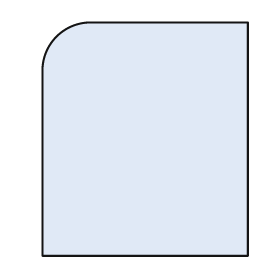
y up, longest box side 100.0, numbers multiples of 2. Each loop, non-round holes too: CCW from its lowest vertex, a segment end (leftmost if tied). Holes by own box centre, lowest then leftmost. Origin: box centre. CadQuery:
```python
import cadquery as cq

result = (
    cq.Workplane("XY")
    .moveTo(-44.0, -50.0)
    .lineTo(44.0, -50.0)
    .lineTo(44.0, 50.0)
    .lineTo(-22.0, 50.0)
    .threePointArc((-38.0, 44.0), (-44.0, 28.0))
    .close()
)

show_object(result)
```